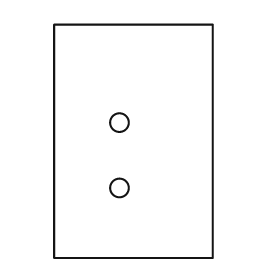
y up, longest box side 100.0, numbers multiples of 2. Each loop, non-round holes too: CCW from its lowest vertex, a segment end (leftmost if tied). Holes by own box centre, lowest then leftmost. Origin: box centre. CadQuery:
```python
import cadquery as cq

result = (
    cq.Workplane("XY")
    .moveTo(-34.0, -50.0)
    .lineTo(34.0, -50.0)
    .lineTo(34.0, 50.0)
    .lineTo(-34.0, 50.0)
    .close()
    .moveTo(-6.0, -20.0)
    .circle(4.0)
    .moveTo(-6.0, 8.0)
    .circle(4.0)
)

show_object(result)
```